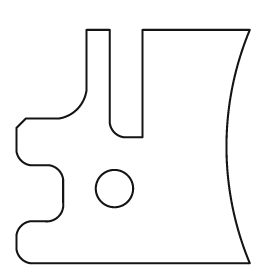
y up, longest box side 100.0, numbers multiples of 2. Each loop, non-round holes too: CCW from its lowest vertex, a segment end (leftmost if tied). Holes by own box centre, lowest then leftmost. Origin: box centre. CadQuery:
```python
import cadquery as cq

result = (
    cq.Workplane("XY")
    .moveTo(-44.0, -50.0)
    .lineTo(50.0, -50.0)
    .threePointArc((40.0, 0.0), (50.0, 50.0))
    .lineTo(4.0, 50.0)
    .lineTo(4.0, 4.0)
    .lineTo(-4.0, 4.0)
    .threePointArc((-8.0, 6.0), (-10.0, 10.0))
    .lineTo(-10.0, 50.0)
    .lineTo(-20.0, 50.0)
    .lineTo(-20.0, 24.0)
    .threePointArc((-24.0, 16.0), (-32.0, 12.0))
    .lineTo(-46.0, 12.0)
    .lineTo(-50.0, 8.0)
    .lineTo(-50.0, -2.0)
    .threePointArc((-48.0, -6.0), (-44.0, -8.0))
    .lineTo(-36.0, -8.0)
    .threePointArc((-32.0, -10.0), (-30.0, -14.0))
    .lineTo(-30.0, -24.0)
    .threePointArc((-32.0, -30.0), (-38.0, -32.0))
    .lineTo(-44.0, -32.0)
    .threePointArc((-48.0, -34.0), (-50.0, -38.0))
    .lineTo(-50.0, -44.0)
    .threePointArc((-48.0, -48.0), (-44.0, -50.0))
    .close()
    .moveTo(-8.0, -18.0)
    .circle(8.0)
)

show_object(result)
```